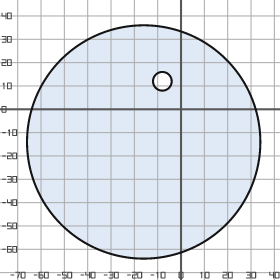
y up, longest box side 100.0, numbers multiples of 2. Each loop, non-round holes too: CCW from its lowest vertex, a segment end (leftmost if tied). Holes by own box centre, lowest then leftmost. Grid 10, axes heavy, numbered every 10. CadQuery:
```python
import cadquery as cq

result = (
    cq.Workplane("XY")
    .moveTo(-16.0, -14.0)
    .circle(50.0)
    .moveTo(-8.0, 12.0)
    .circle(4.0)
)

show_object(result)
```